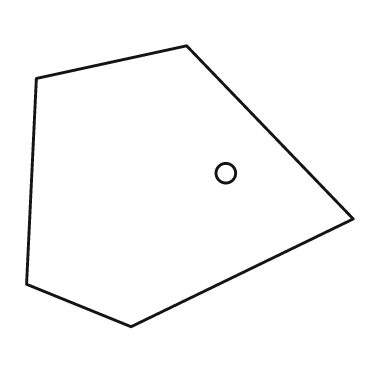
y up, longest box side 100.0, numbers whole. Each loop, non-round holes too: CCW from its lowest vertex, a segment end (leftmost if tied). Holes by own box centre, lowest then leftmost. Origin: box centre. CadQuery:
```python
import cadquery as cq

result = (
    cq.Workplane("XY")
    .moveTo(-18.0, -43.0)
    .lineTo(50.0, -10.0)
    .lineTo(-1.0, 43.0)
    .lineTo(-47.0, 33.0)
    .lineTo(-50.0, -30.0)
    .close()
    .moveTo(11.0, 4.0)
    .circle(3.0)
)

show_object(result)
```